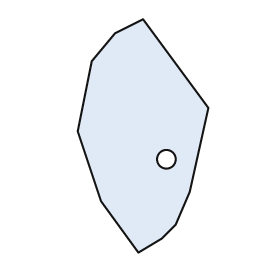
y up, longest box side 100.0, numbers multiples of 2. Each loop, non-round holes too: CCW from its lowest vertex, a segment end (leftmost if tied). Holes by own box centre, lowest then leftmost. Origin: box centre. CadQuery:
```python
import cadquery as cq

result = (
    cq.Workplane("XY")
    .moveTo(-2.0, -50.0)
    .lineTo(8.0, -44.0)
    .lineTo(14.0, -38.0)
    .lineTo(20.0, -24.0)
    .lineTo(28.0, 12.0)
    .lineTo(0.0, 50.0)
    .lineTo(-12.0, 44.0)
    .lineTo(-22.0, 32.0)
    .lineTo(-28.0, 2.0)
    .lineTo(-18.0, -28.0)
    .close()
    .moveTo(10.0, -10.0)
    .circle(4.0)
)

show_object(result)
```